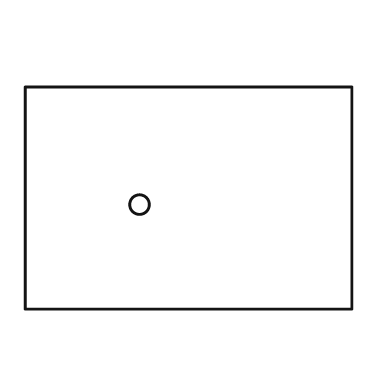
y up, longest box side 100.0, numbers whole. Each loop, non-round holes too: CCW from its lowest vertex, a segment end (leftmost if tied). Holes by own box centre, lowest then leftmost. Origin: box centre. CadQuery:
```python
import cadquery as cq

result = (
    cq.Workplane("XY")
    .moveTo(-50.0, -34.0)
    .lineTo(50.0, -34.0)
    .lineTo(50.0, 34.0)
    .lineTo(-50.0, 34.0)
    .close()
    .moveTo(-15.0, -2.0)
    .circle(3.0)
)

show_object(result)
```